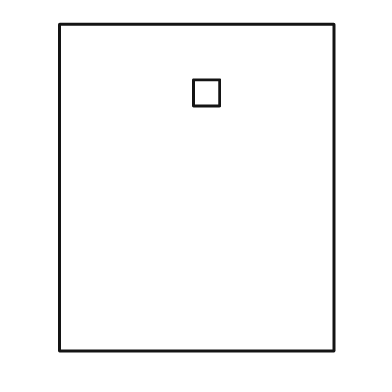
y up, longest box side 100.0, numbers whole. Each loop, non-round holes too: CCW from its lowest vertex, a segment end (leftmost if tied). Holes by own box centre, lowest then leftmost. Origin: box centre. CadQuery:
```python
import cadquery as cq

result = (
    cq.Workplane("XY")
    .moveTo(-42.0, -50.0)
    .lineTo(42.0, -50.0)
    .lineTo(42.0, 50.0)
    .lineTo(-42.0, 50.0)
    .close()
    .moveTo(-1.0, 25.0)
    .lineTo(7.0, 25.0)
    .lineTo(7.0, 33.0)
    .lineTo(-1.0, 33.0)
    .close()
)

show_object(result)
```